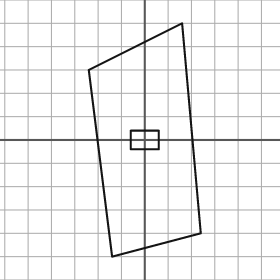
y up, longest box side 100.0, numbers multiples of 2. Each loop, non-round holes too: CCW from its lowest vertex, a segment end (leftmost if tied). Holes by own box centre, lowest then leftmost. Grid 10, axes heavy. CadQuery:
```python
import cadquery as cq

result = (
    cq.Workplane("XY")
    .moveTo(-14.0, -50.0)
    .lineTo(24.0, -40.0)
    .lineTo(16.0, 50.0)
    .lineTo(-24.0, 30.0)
    .close()
    .moveTo(-6.0, -4.0)
    .lineTo(6.0, -4.0)
    .lineTo(6.0, 4.0)
    .lineTo(-6.0, 4.0)
    .close()
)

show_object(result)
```